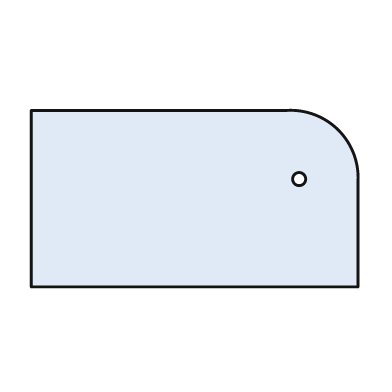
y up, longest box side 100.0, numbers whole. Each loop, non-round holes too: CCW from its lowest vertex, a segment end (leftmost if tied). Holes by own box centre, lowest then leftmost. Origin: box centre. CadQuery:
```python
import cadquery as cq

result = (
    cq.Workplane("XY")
    .moveTo(-50.0, -27.0)
    .lineTo(50.0, -27.0)
    .lineTo(50.0, 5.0)
    .threePointArc((44.0, 21.0), (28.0, 27.0))
    .lineTo(-50.0, 27.0)
    .close()
    .moveTo(32.0, 6.0)
    .circle(2.0)
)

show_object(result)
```